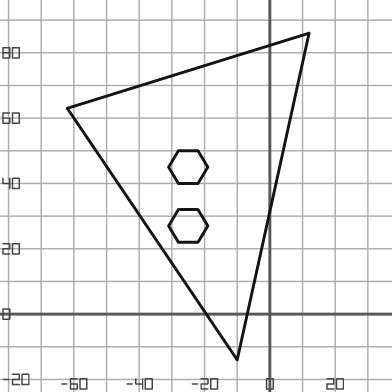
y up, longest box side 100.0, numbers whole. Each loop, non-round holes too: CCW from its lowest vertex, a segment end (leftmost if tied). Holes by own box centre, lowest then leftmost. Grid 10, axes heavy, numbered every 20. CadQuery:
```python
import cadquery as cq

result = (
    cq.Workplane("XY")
    .moveTo(-10.0, -14.0)
    .lineTo(12.0, 86.0)
    .lineTo(-62.0, 63.0)
    .close()
    .moveTo(-28.0, 22.0)
    .lineTo(-22.0, 22.0)
    .lineTo(-19.0, 27.0)
    .lineTo(-22.0, 32.0)
    .lineTo(-28.0, 32.0)
    .lineTo(-31.0, 27.0)
    .close()
    .moveTo(-28.0, 40.0)
    .lineTo(-22.0, 40.0)
    .lineTo(-19.0, 45.0)
    .lineTo(-22.0, 50.0)
    .lineTo(-28.0, 50.0)
    .lineTo(-31.0, 45.0)
    .close()
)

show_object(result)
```